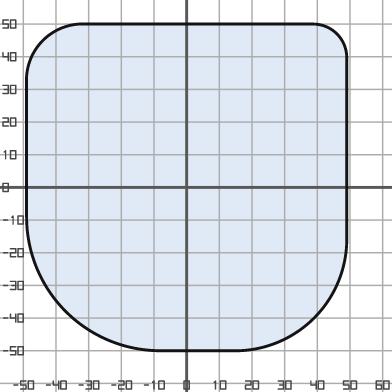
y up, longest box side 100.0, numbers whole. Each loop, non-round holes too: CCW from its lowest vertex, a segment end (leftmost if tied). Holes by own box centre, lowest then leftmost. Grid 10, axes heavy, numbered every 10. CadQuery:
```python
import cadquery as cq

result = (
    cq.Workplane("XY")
    .moveTo(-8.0, -50.0)
    .lineTo(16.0, -50.0)
    .threePointArc((39.0, -40.0), (49.0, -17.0))
    .lineTo(49.0, 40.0)
    .threePointArc((46.0, 47.0), (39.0, 50.0))
    .lineTo(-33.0, 50.0)
    .threePointArc((-44.0, 45.0), (-49.0, 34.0))
    .lineTo(-49.0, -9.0)
    .threePointArc((-37.0, -38.0), (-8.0, -50.0))
    .close()
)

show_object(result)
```